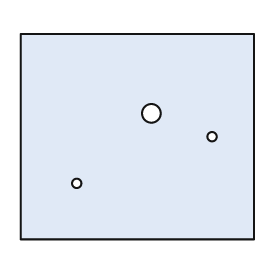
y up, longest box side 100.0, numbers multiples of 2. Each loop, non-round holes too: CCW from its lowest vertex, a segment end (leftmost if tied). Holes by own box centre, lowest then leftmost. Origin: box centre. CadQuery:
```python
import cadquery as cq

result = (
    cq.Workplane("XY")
    .moveTo(-50.0, -44.0)
    .lineTo(50.0, -44.0)
    .lineTo(50.0, 44.0)
    .lineTo(-50.0, 44.0)
    .close()
    .moveTo(-26.0, -20.0)
    .circle(2.0)
    .moveTo(32.0, 0.0)
    .circle(2.0)
    .moveTo(6.0, 10.0)
    .circle(4.0)
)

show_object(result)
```